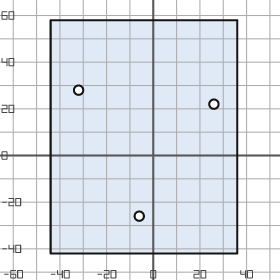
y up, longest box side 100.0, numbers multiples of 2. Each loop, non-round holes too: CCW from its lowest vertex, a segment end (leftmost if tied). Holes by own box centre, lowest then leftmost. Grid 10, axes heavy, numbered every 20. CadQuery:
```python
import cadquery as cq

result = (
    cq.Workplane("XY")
    .moveTo(-44.0, -42.0)
    .lineTo(36.0, -42.0)
    .lineTo(36.0, 58.0)
    .lineTo(-44.0, 58.0)
    .close()
    .moveTo(-6.0, -26.0)
    .circle(2.0)
    .moveTo(26.0, 22.0)
    .circle(2.0)
    .moveTo(-32.0, 28.0)
    .circle(2.0)
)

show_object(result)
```